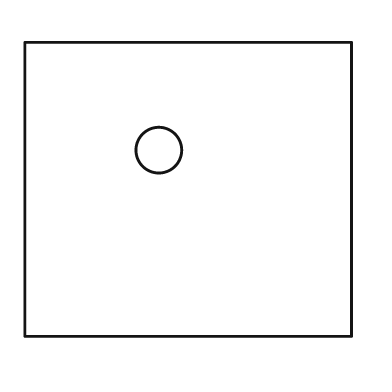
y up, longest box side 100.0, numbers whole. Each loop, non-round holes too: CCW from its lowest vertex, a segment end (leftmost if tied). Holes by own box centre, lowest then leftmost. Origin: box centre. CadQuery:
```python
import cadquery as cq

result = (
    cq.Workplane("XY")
    .moveTo(-50.0, -45.0)
    .lineTo(50.0, -45.0)
    .lineTo(50.0, 45.0)
    .lineTo(-50.0, 45.0)
    .close()
    .moveTo(-9.0, 12.0)
    .circle(7.0)
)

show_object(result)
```